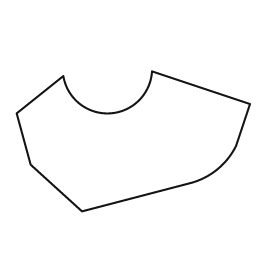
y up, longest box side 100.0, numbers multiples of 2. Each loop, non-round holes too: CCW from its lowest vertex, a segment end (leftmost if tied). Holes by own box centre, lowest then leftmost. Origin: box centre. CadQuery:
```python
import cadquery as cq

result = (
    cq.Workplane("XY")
    .moveTo(-22.0, -30.0)
    .lineTo(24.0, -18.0)
    .threePointArc((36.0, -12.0), (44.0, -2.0))
    .lineTo(50.0, 16.0)
    .lineTo(8.0, 30.0)
    .threePointArc((-10.0, 12.0), (-30.0, 28.0))
    .lineTo(-50.0, 12.0)
    .lineTo(-44.0, -10.0)
    .close()
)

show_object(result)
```